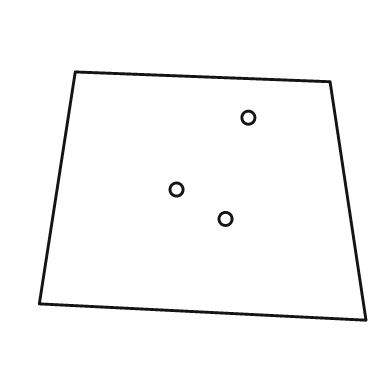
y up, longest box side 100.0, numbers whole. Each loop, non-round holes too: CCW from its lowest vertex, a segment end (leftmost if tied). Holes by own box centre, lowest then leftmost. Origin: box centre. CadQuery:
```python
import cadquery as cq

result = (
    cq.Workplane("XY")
    .moveTo(50.0, -38.0)
    .lineTo(39.0, 35.0)
    .lineTo(-39.0, 38.0)
    .lineTo(-50.0, -33.0)
    .close()
    .moveTo(7.0, -7.0)
    .circle(2.0)
    .moveTo(-8.0, 2.0)
    .circle(2.0)
    .moveTo(14.0, 24.0)
    .circle(2.0)
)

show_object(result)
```